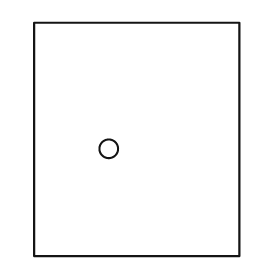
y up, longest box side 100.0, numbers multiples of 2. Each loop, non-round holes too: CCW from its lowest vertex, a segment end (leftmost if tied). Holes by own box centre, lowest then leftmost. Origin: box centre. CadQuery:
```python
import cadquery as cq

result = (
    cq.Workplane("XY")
    .moveTo(-44.0, -50.0)
    .lineTo(44.0, -50.0)
    .lineTo(44.0, 50.0)
    .lineTo(-44.0, 50.0)
    .close()
    .moveTo(-12.0, -4.0)
    .circle(4.0)
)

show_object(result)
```